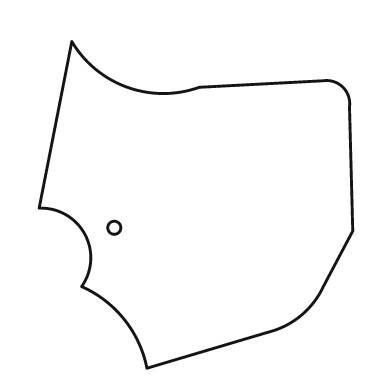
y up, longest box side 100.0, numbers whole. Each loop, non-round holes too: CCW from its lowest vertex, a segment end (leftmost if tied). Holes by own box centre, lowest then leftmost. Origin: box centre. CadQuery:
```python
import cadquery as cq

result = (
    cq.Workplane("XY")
    .moveTo(-15.0, -50.0)
    .lineTo(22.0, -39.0)
    .threePointArc((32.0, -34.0), (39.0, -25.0))
    .lineTo(48.0, -8.0)
    .lineTo(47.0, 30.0)
    .threePointArc((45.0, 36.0), (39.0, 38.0))
    .lineTo(1.0, 36.0)
    .threePointArc((-21.0, 36.0), (-38.0, 50.0))
    .lineTo(-48.0, -1.0)
    .threePointArc((-34.0, -9.0), (-35.0, -25.0))
    .threePointArc((-22.0, -35.0), (-15.0, -50.0))
    .close()
    .moveTo(-25.0, -7.0)
    .circle(2.0)
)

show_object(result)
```